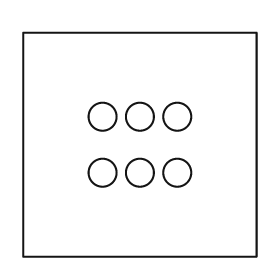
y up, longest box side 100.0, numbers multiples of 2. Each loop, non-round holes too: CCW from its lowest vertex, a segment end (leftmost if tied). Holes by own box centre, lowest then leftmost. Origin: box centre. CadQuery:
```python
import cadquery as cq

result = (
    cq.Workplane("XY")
    .moveTo(-50.0, -48.0)
    .lineTo(50.0, -48.0)
    .lineTo(50.0, 48.0)
    .lineTo(-50.0, 48.0)
    .close()
    .moveTo(-16.0, -12.0)
    .circle(6.0)
    .moveTo(0.0, -12.0)
    .circle(6.0)
    .moveTo(16.0, -12.0)
    .circle(6.0)
    .moveTo(-16.0, 12.0)
    .circle(6.0)
    .moveTo(0.0, 12.0)
    .circle(6.0)
    .moveTo(16.0, 12.0)
    .circle(6.0)
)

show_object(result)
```